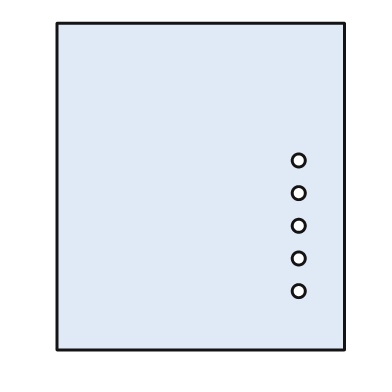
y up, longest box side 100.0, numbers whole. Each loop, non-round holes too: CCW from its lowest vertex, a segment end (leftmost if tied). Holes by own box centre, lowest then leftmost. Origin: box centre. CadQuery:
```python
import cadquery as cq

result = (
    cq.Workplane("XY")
    .moveTo(-44.0, -50.0)
    .lineTo(44.0, -50.0)
    .lineTo(44.0, 50.0)
    .lineTo(-44.0, 50.0)
    .close()
    .moveTo(30.0, -32.0)
    .circle(2.0)
    .moveTo(30.0, -22.0)
    .circle(2.0)
    .moveTo(30.0, -12.0)
    .circle(2.0)
    .moveTo(30.0, -2.0)
    .circle(2.0)
    .moveTo(30.0, 8.0)
    .circle(2.0)
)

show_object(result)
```